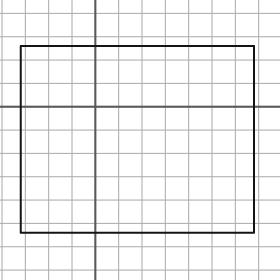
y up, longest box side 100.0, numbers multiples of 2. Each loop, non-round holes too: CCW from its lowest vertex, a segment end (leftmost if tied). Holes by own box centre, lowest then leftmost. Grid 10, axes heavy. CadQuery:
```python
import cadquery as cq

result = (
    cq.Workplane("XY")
    .moveTo(-32.0, -54.0)
    .lineTo(68.0, -54.0)
    .lineTo(68.0, 26.0)
    .lineTo(-32.0, 26.0)
    .close()
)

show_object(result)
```